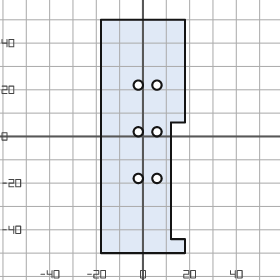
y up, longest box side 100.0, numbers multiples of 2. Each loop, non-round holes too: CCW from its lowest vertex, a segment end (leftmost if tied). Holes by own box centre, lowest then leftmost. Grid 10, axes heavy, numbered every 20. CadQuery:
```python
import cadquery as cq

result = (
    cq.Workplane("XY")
    .moveTo(-18.0, -50.0)
    .lineTo(18.0, -50.0)
    .lineTo(18.0, -44.0)
    .lineTo(12.0, -44.0)
    .lineTo(12.0, 6.0)
    .lineTo(18.0, 6.0)
    .lineTo(18.0, 50.0)
    .lineTo(-18.0, 50.0)
    .close()
    .moveTo(-2.0, -18.0)
    .circle(2.0)
    .moveTo(6.0, -18.0)
    .circle(2.0)
    .moveTo(-2.0, 2.0)
    .circle(2.0)
    .moveTo(6.0, 2.0)
    .circle(2.0)
    .moveTo(-2.0, 22.0)
    .circle(2.0)
    .moveTo(6.0, 22.0)
    .circle(2.0)
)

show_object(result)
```